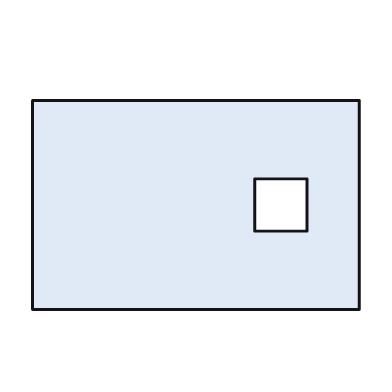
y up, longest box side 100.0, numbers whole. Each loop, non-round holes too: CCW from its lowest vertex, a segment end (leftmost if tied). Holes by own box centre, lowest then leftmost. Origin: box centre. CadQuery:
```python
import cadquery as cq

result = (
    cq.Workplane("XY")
    .moveTo(-50.0, -32.0)
    .lineTo(50.0, -32.0)
    .lineTo(50.0, 32.0)
    .lineTo(-50.0, 32.0)
    .close()
    .moveTo(18.0, -8.0)
    .lineTo(34.0, -8.0)
    .lineTo(34.0, 8.0)
    .lineTo(18.0, 8.0)
    .close()
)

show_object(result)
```